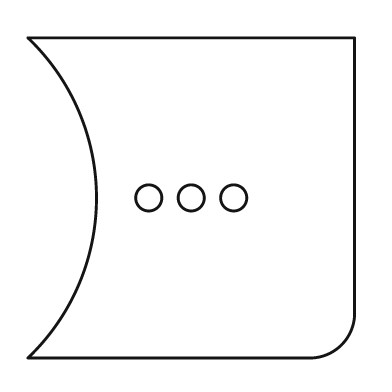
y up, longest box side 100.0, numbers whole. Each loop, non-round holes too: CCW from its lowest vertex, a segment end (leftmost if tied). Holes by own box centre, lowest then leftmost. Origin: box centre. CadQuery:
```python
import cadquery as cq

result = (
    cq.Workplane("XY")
    .moveTo(-50.0, -49.0)
    .lineTo(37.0, -49.0)
    .threePointArc((46.0, -45.0), (50.0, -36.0))
    .lineTo(50.0, 49.0)
    .lineTo(-50.0, 49.0)
    .threePointArc((-29.0, 0.0), (-50.0, -49.0))
    .close()
    .moveTo(-13.0, 0.0)
    .circle(4.0)
    .moveTo(0.0, 0.0)
    .circle(4.0)
    .moveTo(13.0, 0.0)
    .circle(4.0)
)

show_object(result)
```